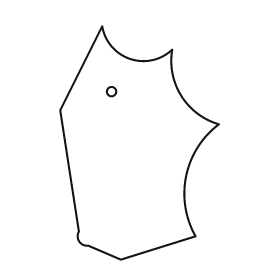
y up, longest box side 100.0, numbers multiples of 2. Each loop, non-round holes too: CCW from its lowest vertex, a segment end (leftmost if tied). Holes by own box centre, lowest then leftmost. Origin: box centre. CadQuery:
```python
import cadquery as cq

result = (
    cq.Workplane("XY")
    .moveTo(-8.0, -50.0)
    .lineTo(24.0, -40.0)
    .threePointArc((20.0, -14.0), (34.0, 8.0))
    .threePointArc((18.0, 20.0), (14.0, 40.0))
    .threePointArc((-4.0, 36.0), (-16.0, 50.0))
    .lineTo(-34.0, 14.0)
    .lineTo(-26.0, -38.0)
    .threePointArc((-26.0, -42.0), (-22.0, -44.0))
    .close()
    .moveTo(-12.0, 22.0)
    .circle(2.0)
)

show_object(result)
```